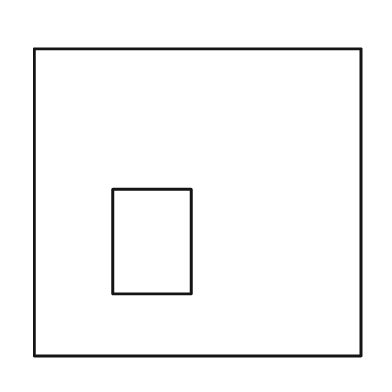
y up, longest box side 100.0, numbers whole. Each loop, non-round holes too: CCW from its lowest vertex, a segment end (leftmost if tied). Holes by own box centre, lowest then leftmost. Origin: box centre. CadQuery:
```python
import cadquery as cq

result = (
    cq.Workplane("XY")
    .moveTo(-50.0, -47.0)
    .lineTo(50.0, -47.0)
    .lineTo(50.0, 47.0)
    .lineTo(-50.0, 47.0)
    .close()
    .moveTo(-26.0, -28.0)
    .lineTo(-2.0, -28.0)
    .lineTo(-2.0, 4.0)
    .lineTo(-26.0, 4.0)
    .close()
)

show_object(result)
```